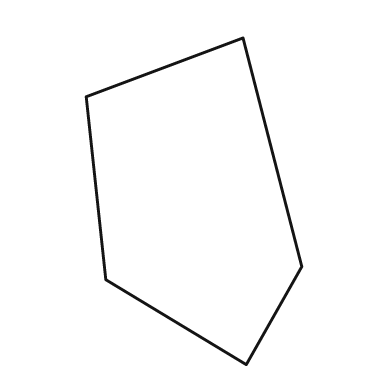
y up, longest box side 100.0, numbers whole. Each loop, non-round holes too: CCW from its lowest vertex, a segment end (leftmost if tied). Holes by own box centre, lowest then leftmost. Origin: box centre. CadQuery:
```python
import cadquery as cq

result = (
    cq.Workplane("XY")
    .moveTo(16.0, -50.0)
    .lineTo(33.0, -20.0)
    .lineTo(15.0, 50.0)
    .lineTo(-33.0, 32.0)
    .lineTo(-27.0, -24.0)
    .close()
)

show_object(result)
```